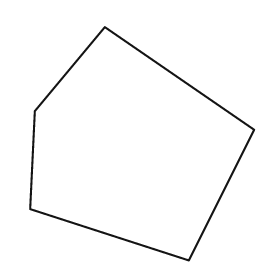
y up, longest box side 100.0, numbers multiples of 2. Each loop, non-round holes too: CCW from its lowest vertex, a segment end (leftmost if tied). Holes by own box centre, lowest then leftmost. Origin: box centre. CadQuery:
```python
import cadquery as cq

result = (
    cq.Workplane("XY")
    .moveTo(20.0, -50.0)
    .lineTo(48.0, 6.0)
    .lineTo(-16.0, 50.0)
    .lineTo(-46.0, 14.0)
    .lineTo(-48.0, -28.0)
    .close()
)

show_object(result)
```